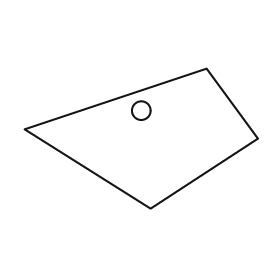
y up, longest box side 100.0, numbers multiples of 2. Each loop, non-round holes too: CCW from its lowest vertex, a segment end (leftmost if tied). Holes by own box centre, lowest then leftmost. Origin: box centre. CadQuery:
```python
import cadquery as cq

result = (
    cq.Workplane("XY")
    .moveTo(4.0, -30.0)
    .lineTo(50.0, 0.0)
    .lineTo(28.0, 30.0)
    .lineTo(-50.0, 4.0)
    .close()
    .moveTo(0.0, 12.0)
    .circle(4.0)
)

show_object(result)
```